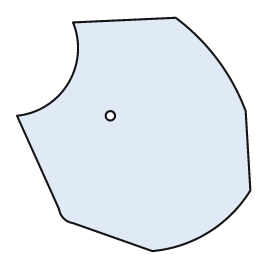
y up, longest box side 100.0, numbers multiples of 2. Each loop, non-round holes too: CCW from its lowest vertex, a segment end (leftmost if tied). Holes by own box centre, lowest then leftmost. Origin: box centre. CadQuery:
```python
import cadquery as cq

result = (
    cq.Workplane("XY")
    .moveTo(8.0, -50.0)
    .threePointArc((32.0, -42.0), (50.0, -24.0))
    .lineTo(48.0, 10.0)
    .threePointArc((36.0, 32.0), (18.0, 50.0))
    .lineTo(-26.0, 48.0)
    .threePointArc((-28.0, 22.0), (-50.0, 8.0))
    .lineTo(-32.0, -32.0)
    .threePointArc((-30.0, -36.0), (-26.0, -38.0))
    .close()
    .moveTo(-10.0, 8.0)
    .circle(2.0)
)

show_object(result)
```